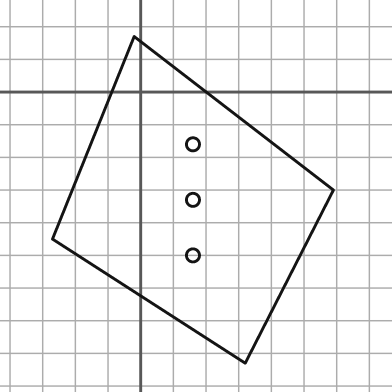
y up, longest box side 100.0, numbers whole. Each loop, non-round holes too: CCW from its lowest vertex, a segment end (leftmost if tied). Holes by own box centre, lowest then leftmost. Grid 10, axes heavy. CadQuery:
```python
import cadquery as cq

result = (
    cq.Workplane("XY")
    .moveTo(32.0, -83.0)
    .lineTo(59.0, -30.0)
    .lineTo(-2.0, 17.0)
    .lineTo(-27.0, -45.0)
    .close()
    .moveTo(16.0, -50.0)
    .circle(2.0)
    .moveTo(16.0, -33.0)
    .circle(2.0)
    .moveTo(16.0, -16.0)
    .circle(2.0)
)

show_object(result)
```